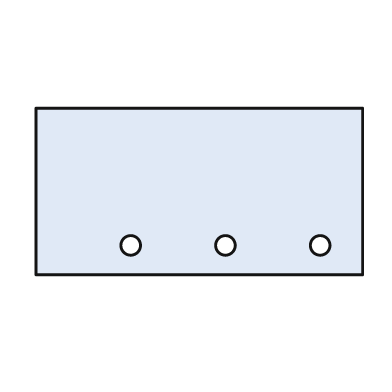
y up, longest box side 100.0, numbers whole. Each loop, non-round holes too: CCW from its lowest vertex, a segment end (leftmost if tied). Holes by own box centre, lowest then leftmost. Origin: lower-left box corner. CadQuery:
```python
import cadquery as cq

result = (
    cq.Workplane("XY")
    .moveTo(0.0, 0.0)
    .lineTo(100.0, 0.0)
    .lineTo(100.0, 51.0)
    .lineTo(0.0, 51.0)
    .close()
    .moveTo(29.0, 9.0)
    .circle(3.0)
    .moveTo(58.0, 9.0)
    .circle(3.0)
    .moveTo(87.0, 9.0)
    .circle(3.0)
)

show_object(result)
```